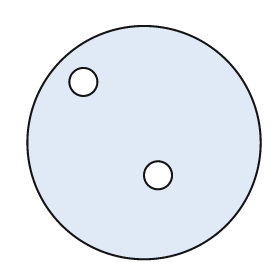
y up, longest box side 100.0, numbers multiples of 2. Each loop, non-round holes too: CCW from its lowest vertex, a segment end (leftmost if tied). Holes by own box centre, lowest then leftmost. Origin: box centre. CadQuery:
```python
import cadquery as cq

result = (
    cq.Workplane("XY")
    .moveTo(0.0, 0.0)
    .circle(50.0)
    .moveTo(6.0, -14.0)
    .circle(6.0)
    .moveTo(-26.0, 26.0)
    .circle(6.0)
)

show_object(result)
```